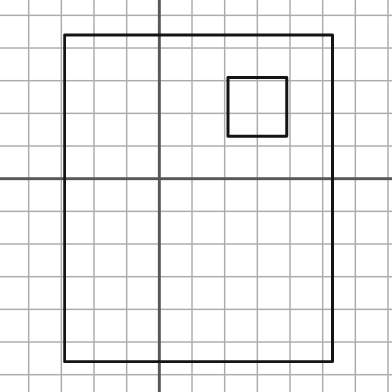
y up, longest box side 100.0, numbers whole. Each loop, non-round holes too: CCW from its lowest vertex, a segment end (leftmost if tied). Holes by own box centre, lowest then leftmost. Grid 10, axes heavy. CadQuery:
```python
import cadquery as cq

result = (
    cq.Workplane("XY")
    .moveTo(-29.0, -56.0)
    .lineTo(53.0, -56.0)
    .lineTo(53.0, 44.0)
    .lineTo(-29.0, 44.0)
    .close()
    .moveTo(21.0, 13.0)
    .lineTo(39.0, 13.0)
    .lineTo(39.0, 31.0)
    .lineTo(21.0, 31.0)
    .close()
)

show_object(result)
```